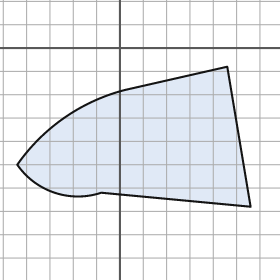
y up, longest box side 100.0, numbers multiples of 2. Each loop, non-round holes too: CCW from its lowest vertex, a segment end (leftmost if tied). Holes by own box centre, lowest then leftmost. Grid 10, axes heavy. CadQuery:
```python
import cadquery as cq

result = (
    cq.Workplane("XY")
    .moveTo(56.0, -68.0)
    .lineTo(46.0, -8.0)
    .lineTo(2.0, -18.0)
    .threePointArc((-24.0, -30.0), (-44.0, -50.0))
    .threePointArc((-28.0, -62.0), (-8.0, -62.0))
    .close()
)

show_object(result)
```